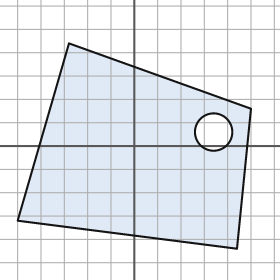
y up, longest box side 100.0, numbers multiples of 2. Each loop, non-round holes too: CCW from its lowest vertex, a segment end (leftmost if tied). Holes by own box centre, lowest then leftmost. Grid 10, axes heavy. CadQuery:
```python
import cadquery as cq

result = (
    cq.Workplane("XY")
    .moveTo(44.0, -44.0)
    .lineTo(50.0, 16.0)
    .lineTo(-28.0, 44.0)
    .lineTo(-50.0, -32.0)
    .close()
    .moveTo(34.0, 6.0)
    .circle(8.0)
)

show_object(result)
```